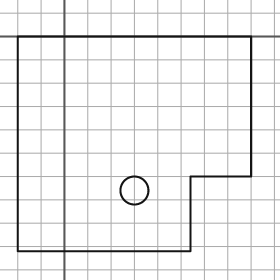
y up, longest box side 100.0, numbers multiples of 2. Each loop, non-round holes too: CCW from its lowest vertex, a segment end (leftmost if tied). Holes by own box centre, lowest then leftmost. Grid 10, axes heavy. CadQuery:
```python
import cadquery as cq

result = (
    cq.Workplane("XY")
    .moveTo(-20.0, -92.0)
    .lineTo(54.0, -92.0)
    .lineTo(54.0, -60.0)
    .lineTo(80.0, -60.0)
    .lineTo(80.0, 0.0)
    .lineTo(-20.0, 0.0)
    .close()
    .moveTo(30.0, -66.0)
    .circle(6.0)
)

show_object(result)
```